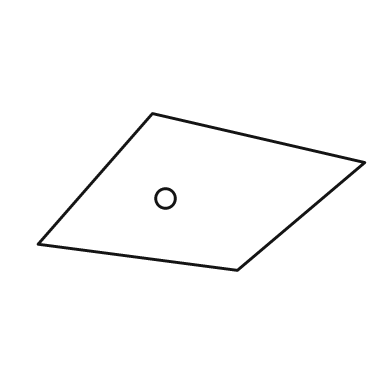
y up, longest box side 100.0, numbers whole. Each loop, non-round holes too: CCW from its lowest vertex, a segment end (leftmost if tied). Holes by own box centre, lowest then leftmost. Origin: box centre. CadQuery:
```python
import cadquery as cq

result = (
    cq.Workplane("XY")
    .moveTo(11.0, -24.0)
    .lineTo(50.0, 9.0)
    .lineTo(-15.0, 24.0)
    .lineTo(-50.0, -16.0)
    .close()
    .moveTo(-11.0, -2.0)
    .circle(3.0)
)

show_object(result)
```